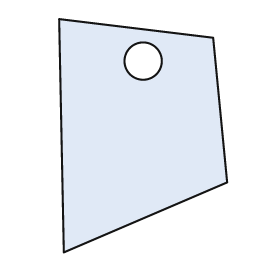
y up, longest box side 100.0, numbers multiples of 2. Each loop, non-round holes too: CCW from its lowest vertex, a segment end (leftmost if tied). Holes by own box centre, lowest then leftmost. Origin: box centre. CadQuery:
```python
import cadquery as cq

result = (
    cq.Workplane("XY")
    .moveTo(-34.0, -50.0)
    .lineTo(36.0, -20.0)
    .lineTo(30.0, 42.0)
    .lineTo(-36.0, 50.0)
    .close()
    .moveTo(0.0, 32.0)
    .circle(8.0)
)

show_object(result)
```